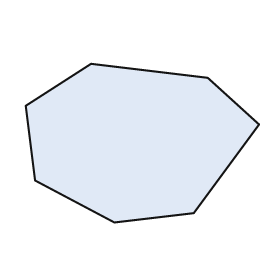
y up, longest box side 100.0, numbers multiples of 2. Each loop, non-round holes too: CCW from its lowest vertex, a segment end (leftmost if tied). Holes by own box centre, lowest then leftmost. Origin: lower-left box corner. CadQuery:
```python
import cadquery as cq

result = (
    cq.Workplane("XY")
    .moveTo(38.0, 0.0)
    .lineTo(72.0, 4.0)
    .lineTo(100.0, 42.0)
    .lineTo(78.0, 62.0)
    .lineTo(28.0, 68.0)
    .lineTo(0.0, 50.0)
    .lineTo(4.0, 18.0)
    .close()
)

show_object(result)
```